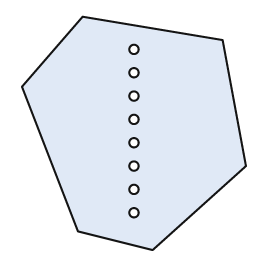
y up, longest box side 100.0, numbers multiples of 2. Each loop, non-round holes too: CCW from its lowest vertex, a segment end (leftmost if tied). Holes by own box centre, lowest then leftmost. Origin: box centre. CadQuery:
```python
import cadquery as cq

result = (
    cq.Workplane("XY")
    .moveTo(8.0, -50.0)
    .lineTo(48.0, -14.0)
    .lineTo(38.0, 40.0)
    .lineTo(-22.0, 50.0)
    .lineTo(-48.0, 20.0)
    .lineTo(-24.0, -42.0)
    .close()
    .moveTo(0.0, -34.0)
    .circle(2.0)
    .moveTo(0.0, -24.0)
    .circle(2.0)
    .moveTo(0.0, -14.0)
    .circle(2.0)
    .moveTo(0.0, -4.0)
    .circle(2.0)
    .moveTo(0.0, 6.0)
    .circle(2.0)
    .moveTo(0.0, 16.0)
    .circle(2.0)
    .moveTo(0.0, 26.0)
    .circle(2.0)
    .moveTo(0.0, 36.0)
    .circle(2.0)
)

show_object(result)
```